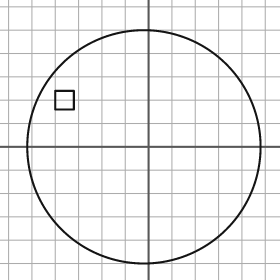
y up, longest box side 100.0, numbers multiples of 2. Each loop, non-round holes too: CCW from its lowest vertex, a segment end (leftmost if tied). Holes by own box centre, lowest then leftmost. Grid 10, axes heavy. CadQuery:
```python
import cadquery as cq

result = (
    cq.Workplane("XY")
    .moveTo(-2.0, 0.0)
    .circle(50.0)
    .moveTo(-40.0, 16.0)
    .lineTo(-32.0, 16.0)
    .lineTo(-32.0, 24.0)
    .lineTo(-40.0, 24.0)
    .close()
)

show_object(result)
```